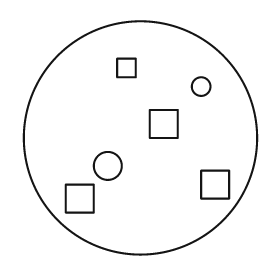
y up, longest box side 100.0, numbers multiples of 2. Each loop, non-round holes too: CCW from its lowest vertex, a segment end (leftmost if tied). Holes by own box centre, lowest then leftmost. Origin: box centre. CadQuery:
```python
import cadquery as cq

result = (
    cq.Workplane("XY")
    .moveTo(0.0, 0.0)
    .circle(50.0)
    .moveTo(-32.0, -32.0)
    .lineTo(-20.0, -32.0)
    .lineTo(-20.0, -20.0)
    .lineTo(-32.0, -20.0)
    .close()
    .moveTo(26.0, -26.0)
    .lineTo(38.0, -26.0)
    .lineTo(38.0, -14.0)
    .lineTo(26.0, -14.0)
    .close()
    .moveTo(-14.0, -12.0)
    .circle(6.0)
    .moveTo(4.0, 0.0)
    .lineTo(16.0, 0.0)
    .lineTo(16.0, 12.0)
    .lineTo(4.0, 12.0)
    .close()
    .moveTo(26.0, 22.0)
    .circle(4.0)
    .moveTo(-10.0, 26.0)
    .lineTo(-2.0, 26.0)
    .lineTo(-2.0, 34.0)
    .lineTo(-10.0, 34.0)
    .close()
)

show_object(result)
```